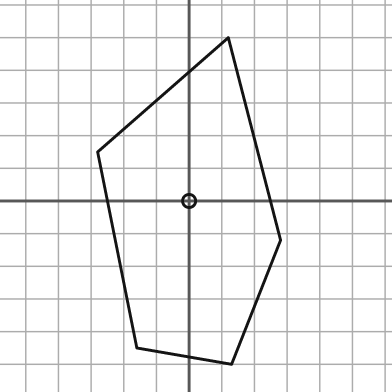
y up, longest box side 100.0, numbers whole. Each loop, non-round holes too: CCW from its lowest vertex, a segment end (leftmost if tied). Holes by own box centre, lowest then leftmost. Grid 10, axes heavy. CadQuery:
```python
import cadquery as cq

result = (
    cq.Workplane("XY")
    .moveTo(13.0, -50.0)
    .lineTo(28.0, -12.0)
    .lineTo(12.0, 50.0)
    .lineTo(-28.0, 15.0)
    .lineTo(-16.0, -45.0)
    .close()
    .moveTo(0.0, 0.0)
    .circle(2.0)
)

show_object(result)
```